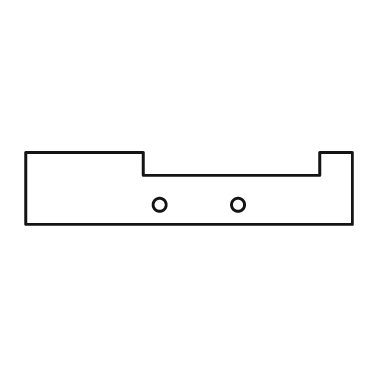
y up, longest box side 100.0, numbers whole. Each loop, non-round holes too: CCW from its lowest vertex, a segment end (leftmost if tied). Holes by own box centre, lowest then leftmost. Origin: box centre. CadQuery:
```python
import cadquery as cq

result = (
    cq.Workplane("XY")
    .moveTo(-50.0, -11.0)
    .lineTo(50.0, -11.0)
    .lineTo(50.0, 11.0)
    .lineTo(40.0, 11.0)
    .lineTo(40.0, 4.0)
    .lineTo(-14.0, 4.0)
    .lineTo(-14.0, 11.0)
    .lineTo(-50.0, 11.0)
    .close()
    .moveTo(-9.0, -5.0)
    .circle(2.0)
    .moveTo(15.0, -5.0)
    .circle(2.0)
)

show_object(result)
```